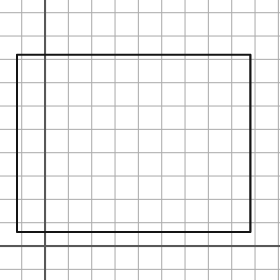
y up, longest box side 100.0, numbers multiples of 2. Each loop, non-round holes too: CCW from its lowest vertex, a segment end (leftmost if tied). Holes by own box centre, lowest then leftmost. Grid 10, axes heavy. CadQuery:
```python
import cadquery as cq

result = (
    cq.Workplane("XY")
    .moveTo(-12.0, 6.0)
    .lineTo(88.0, 6.0)
    .lineTo(88.0, 82.0)
    .lineTo(-12.0, 82.0)
    .close()
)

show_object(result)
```